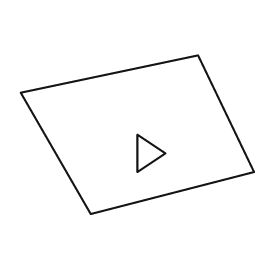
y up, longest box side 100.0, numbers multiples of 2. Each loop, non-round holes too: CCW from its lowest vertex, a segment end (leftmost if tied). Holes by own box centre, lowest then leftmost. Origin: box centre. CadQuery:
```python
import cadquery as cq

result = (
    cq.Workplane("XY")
    .moveTo(-20.0, -34.0)
    .lineTo(50.0, -16.0)
    .lineTo(26.0, 34.0)
    .lineTo(-50.0, 18.0)
    .close()
    .moveTo(0.0, -16.0)
    .lineTo(12.0, -8.0)
    .lineTo(0.0, 0.0)
    .close()
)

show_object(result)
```